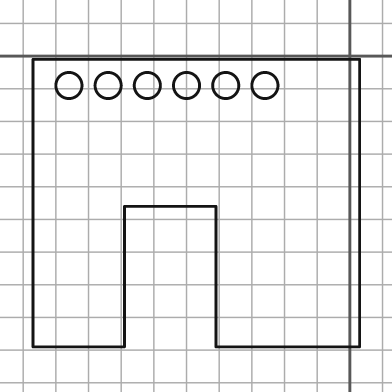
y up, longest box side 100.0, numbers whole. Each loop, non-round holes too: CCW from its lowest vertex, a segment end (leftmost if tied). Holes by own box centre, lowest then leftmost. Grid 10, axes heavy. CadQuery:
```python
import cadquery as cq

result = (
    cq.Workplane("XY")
    .moveTo(-97.0, -89.0)
    .lineTo(-69.0, -89.0)
    .lineTo(-69.0, -46.0)
    .lineTo(-41.0, -46.0)
    .lineTo(-41.0, -89.0)
    .lineTo(3.0, -89.0)
    .lineTo(3.0, -1.0)
    .lineTo(-97.0, -1.0)
    .close()
    .moveTo(-86.0, -9.0)
    .circle(4.0)
    .moveTo(-74.0, -9.0)
    .circle(4.0)
    .moveTo(-62.0, -9.0)
    .circle(4.0)
    .moveTo(-50.0, -9.0)
    .circle(4.0)
    .moveTo(-38.0, -9.0)
    .circle(4.0)
    .moveTo(-26.0, -9.0)
    .circle(4.0)
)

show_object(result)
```